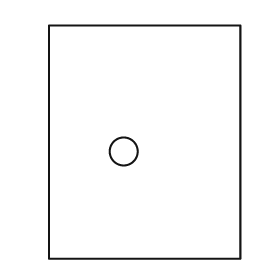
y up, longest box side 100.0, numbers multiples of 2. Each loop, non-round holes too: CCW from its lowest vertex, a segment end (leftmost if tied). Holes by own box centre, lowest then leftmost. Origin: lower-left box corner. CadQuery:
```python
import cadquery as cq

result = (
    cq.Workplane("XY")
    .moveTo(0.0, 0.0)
    .lineTo(82.0, 0.0)
    .lineTo(82.0, 100.0)
    .lineTo(0.0, 100.0)
    .close()
    .moveTo(32.0, 46.0)
    .circle(6.0)
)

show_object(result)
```